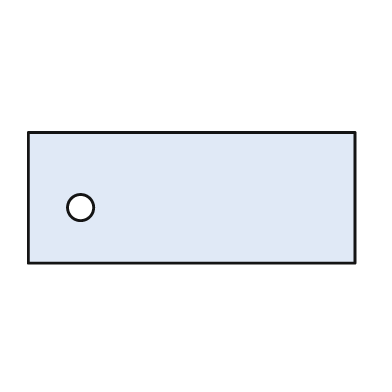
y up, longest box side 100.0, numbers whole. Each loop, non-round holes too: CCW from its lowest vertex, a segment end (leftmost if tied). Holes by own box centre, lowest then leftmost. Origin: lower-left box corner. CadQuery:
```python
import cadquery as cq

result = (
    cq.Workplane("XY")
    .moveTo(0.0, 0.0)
    .lineTo(100.0, 0.0)
    .lineTo(100.0, 40.0)
    .lineTo(0.0, 40.0)
    .close()
    .moveTo(16.0, 17.0)
    .circle(4.0)
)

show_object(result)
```